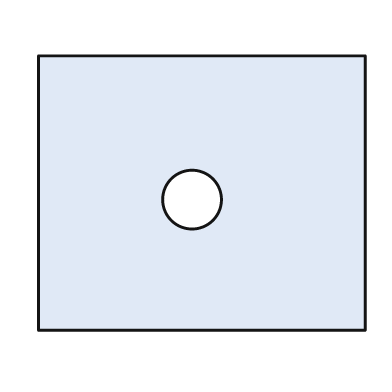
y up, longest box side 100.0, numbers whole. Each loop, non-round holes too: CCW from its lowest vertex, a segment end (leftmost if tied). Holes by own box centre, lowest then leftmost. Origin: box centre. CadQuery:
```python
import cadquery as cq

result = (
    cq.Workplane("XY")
    .moveTo(-50.0, -42.0)
    .lineTo(50.0, -42.0)
    .lineTo(50.0, 42.0)
    .lineTo(-50.0, 42.0)
    .close()
    .moveTo(-3.0, -2.0)
    .circle(9.0)
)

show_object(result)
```